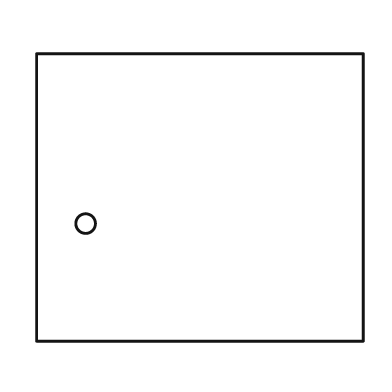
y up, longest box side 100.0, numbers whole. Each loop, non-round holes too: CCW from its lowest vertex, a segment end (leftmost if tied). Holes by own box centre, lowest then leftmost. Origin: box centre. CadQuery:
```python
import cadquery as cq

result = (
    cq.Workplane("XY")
    .moveTo(-50.0, -44.0)
    .lineTo(50.0, -44.0)
    .lineTo(50.0, 44.0)
    .lineTo(-50.0, 44.0)
    .close()
    .moveTo(-35.0, -8.0)
    .circle(3.0)
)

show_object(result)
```